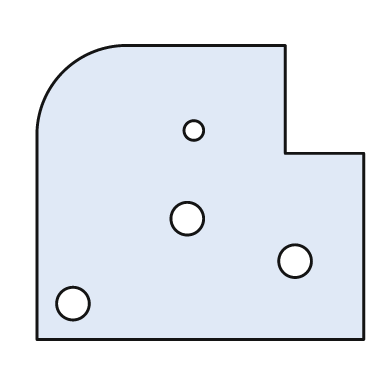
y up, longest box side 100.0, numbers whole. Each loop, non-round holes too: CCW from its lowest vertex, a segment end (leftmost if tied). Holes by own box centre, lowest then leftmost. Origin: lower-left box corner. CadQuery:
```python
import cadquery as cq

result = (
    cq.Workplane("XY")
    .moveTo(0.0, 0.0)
    .lineTo(100.0, 0.0)
    .lineTo(100.0, 57.0)
    .lineTo(76.0, 57.0)
    .lineTo(76.0, 90.0)
    .lineTo(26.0, 90.0)
    .threePointArc((8.0, 82.0), (0.0, 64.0))
    .close()
    .moveTo(11.0, 11.0)
    .circle(5.0)
    .moveTo(79.0, 24.0)
    .circle(5.0)
    .moveTo(46.0, 37.0)
    .circle(5.0)
    .moveTo(48.0, 64.0)
    .circle(3.0)
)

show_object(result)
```